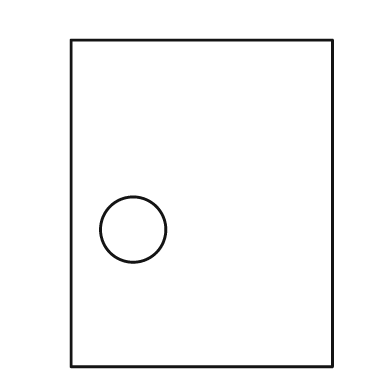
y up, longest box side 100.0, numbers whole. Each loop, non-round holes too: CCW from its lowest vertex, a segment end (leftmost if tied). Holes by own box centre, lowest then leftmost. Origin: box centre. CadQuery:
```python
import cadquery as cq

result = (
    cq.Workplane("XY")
    .moveTo(-40.0, -50.0)
    .lineTo(40.0, -50.0)
    .lineTo(40.0, 50.0)
    .lineTo(-40.0, 50.0)
    .close()
    .moveTo(-21.0, -8.0)
    .circle(10.0)
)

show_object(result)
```